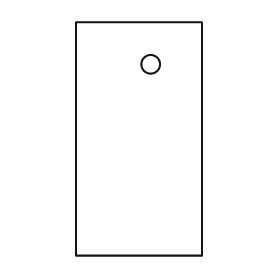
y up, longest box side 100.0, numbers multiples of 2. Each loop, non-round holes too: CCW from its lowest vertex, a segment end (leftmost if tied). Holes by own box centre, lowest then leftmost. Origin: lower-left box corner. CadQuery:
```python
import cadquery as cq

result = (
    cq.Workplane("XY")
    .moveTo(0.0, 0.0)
    .lineTo(54.0, 0.0)
    .lineTo(54.0, 100.0)
    .lineTo(0.0, 100.0)
    .close()
    .moveTo(32.0, 82.0)
    .circle(4.0)
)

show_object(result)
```